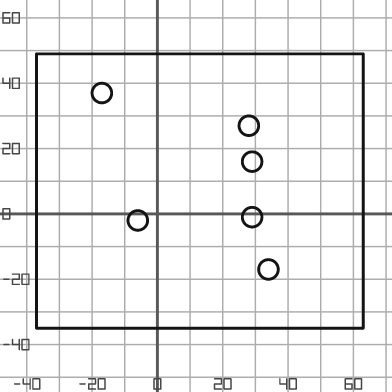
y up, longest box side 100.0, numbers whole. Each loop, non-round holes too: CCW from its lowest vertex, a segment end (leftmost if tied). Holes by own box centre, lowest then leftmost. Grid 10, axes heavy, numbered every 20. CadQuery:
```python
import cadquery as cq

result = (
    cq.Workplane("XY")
    .moveTo(-37.0, -35.0)
    .lineTo(63.0, -35.0)
    .lineTo(63.0, 49.0)
    .lineTo(-37.0, 49.0)
    .close()
    .moveTo(34.0, -17.0)
    .circle(3.0)
    .moveTo(-6.0, -2.0)
    .circle(3.0)
    .moveTo(29.0, -1.0)
    .circle(3.0)
    .moveTo(29.0, 16.0)
    .circle(3.0)
    .moveTo(28.0, 27.0)
    .circle(3.0)
    .moveTo(-17.0, 37.0)
    .circle(3.0)
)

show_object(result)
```